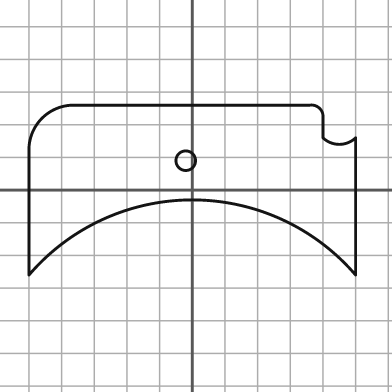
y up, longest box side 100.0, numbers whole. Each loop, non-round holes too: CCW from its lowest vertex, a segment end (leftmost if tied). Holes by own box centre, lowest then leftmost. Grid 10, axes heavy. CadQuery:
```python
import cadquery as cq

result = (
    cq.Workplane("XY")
    .moveTo(-50.0, -26.0)
    .threePointArc((0.0, -3.0), (50.0, -26.0))
    .lineTo(50.0, 16.0)
    .threePointArc((45.0, 14.0), (40.0, 16.0))
    .lineTo(40.0, 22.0)
    .threePointArc((39.0, 25.0), (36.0, 26.0))
    .lineTo(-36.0, 26.0)
    .threePointArc((-46.0, 22.0), (-50.0, 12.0))
    .close()
    .moveTo(-2.0, 9.0)
    .circle(3.0)
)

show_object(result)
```